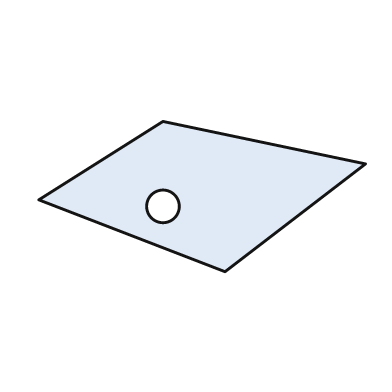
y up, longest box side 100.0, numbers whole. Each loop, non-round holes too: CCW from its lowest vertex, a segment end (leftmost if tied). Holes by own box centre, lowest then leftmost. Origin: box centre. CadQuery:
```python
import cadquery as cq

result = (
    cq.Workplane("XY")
    .moveTo(7.0, -23.0)
    .lineTo(50.0, 10.0)
    .lineTo(-12.0, 23.0)
    .lineTo(-50.0, -1.0)
    .close()
    .moveTo(-12.0, -3.0)
    .circle(5.0)
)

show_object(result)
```